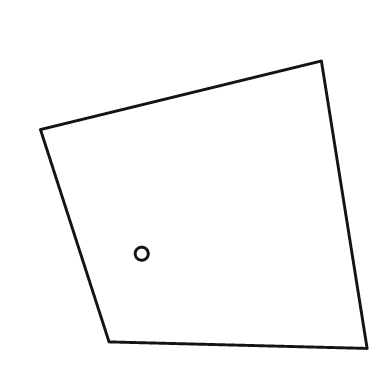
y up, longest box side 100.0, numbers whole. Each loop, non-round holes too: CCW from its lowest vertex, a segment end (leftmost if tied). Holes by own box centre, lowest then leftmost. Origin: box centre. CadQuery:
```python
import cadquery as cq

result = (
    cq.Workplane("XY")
    .moveTo(50.0, -44.0)
    .lineTo(36.0, 44.0)
    .lineTo(-50.0, 23.0)
    .lineTo(-29.0, -42.0)
    .close()
    .moveTo(-19.0, -15.0)
    .circle(2.0)
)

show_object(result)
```